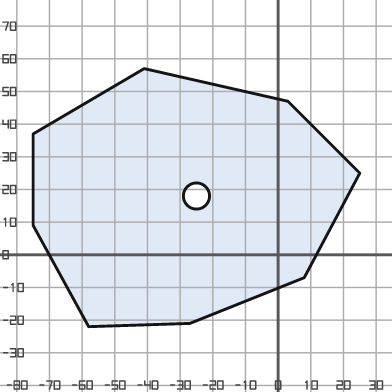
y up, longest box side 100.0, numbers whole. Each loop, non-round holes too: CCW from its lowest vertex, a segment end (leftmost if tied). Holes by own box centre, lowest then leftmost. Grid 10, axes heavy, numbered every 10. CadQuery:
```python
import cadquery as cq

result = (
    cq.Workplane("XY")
    .moveTo(-58.0, -22.0)
    .lineTo(-27.0, -21.0)
    .lineTo(8.0, -7.0)
    .lineTo(25.0, 25.0)
    .lineTo(3.0, 47.0)
    .lineTo(-41.0, 57.0)
    .lineTo(-75.0, 37.0)
    .lineTo(-75.0, 9.0)
    .close()
    .moveTo(-25.0, 18.0)
    .circle(4.0)
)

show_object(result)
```